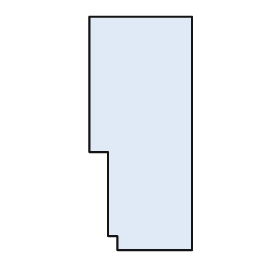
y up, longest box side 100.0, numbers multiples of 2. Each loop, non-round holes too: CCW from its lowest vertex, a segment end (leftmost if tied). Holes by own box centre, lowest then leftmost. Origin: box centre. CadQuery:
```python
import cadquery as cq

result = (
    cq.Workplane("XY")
    .moveTo(-10.0, -50.0)
    .lineTo(22.0, -50.0)
    .lineTo(22.0, 50.0)
    .lineTo(-22.0, 50.0)
    .lineTo(-22.0, -8.0)
    .lineTo(-14.0, -8.0)
    .lineTo(-14.0, -44.0)
    .lineTo(-10.0, -44.0)
    .close()
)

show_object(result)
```